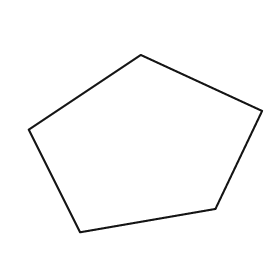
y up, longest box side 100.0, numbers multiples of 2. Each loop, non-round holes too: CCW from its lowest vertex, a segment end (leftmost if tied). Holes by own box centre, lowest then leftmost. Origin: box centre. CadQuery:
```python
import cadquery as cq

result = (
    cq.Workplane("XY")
    .moveTo(-28.0, -38.0)
    .lineTo(30.0, -28.0)
    .lineTo(50.0, 14.0)
    .lineTo(-2.0, 38.0)
    .lineTo(-50.0, 6.0)
    .close()
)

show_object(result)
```